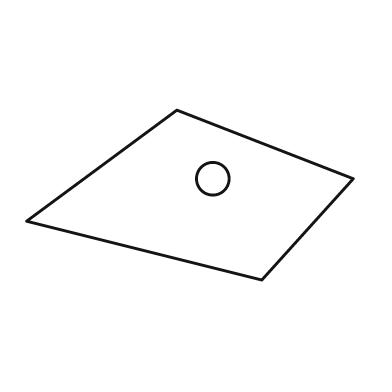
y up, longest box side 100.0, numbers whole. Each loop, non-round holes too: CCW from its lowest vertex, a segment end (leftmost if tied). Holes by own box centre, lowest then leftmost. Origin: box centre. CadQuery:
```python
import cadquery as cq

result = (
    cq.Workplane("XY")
    .moveTo(22.0, -26.0)
    .lineTo(50.0, 5.0)
    .lineTo(-4.0, 26.0)
    .lineTo(-50.0, -8.0)
    .close()
    .moveTo(7.0, 5.0)
    .circle(5.0)
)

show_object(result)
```